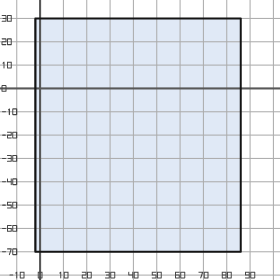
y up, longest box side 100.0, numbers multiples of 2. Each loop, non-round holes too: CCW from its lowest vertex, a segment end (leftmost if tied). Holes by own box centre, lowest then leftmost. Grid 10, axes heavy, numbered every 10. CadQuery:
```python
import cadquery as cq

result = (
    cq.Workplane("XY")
    .moveTo(-2.0, -70.0)
    .lineTo(86.0, -70.0)
    .lineTo(86.0, 30.0)
    .lineTo(-2.0, 30.0)
    .close()
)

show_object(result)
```